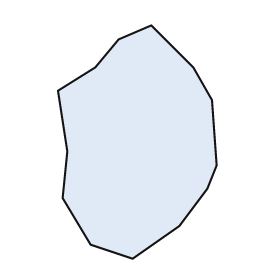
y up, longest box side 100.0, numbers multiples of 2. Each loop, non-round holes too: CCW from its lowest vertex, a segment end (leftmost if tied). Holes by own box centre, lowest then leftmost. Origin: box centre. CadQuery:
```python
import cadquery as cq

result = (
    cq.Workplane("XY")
    .moveTo(-2.0, -50.0)
    .lineTo(18.0, -36.0)
    .lineTo(30.0, -20.0)
    .lineTo(34.0, -10.0)
    .lineTo(32.0, 18.0)
    .lineTo(24.0, 32.0)
    .lineTo(6.0, 50.0)
    .lineTo(-8.0, 44.0)
    .lineTo(-18.0, 32.0)
    .lineTo(-34.0, 22.0)
    .lineTo(-30.0, -4.0)
    .lineTo(-32.0, -24.0)
    .lineTo(-20.0, -44.0)
    .close()
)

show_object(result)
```